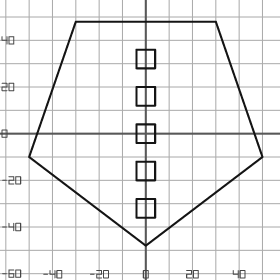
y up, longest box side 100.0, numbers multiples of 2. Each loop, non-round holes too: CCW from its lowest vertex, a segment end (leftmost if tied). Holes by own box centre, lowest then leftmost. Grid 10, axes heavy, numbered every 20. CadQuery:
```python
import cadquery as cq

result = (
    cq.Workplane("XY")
    .moveTo(0.0, -48.0)
    .lineTo(50.0, -10.0)
    .lineTo(30.0, 48.0)
    .lineTo(-30.0, 48.0)
    .lineTo(-50.0, -10.0)
    .close()
    .moveTo(-4.0, -36.0)
    .lineTo(4.0, -36.0)
    .lineTo(4.0, -28.0)
    .lineTo(-4.0, -28.0)
    .close()
    .moveTo(-4.0, -20.0)
    .lineTo(4.0, -20.0)
    .lineTo(4.0, -12.0)
    .lineTo(-4.0, -12.0)
    .close()
    .moveTo(-4.0, -4.0)
    .lineTo(4.0, -4.0)
    .lineTo(4.0, 4.0)
    .lineTo(-4.0, 4.0)
    .close()
    .moveTo(-4.0, 12.0)
    .lineTo(4.0, 12.0)
    .lineTo(4.0, 20.0)
    .lineTo(-4.0, 20.0)
    .close()
    .moveTo(-4.0, 28.0)
    .lineTo(4.0, 28.0)
    .lineTo(4.0, 36.0)
    .lineTo(-4.0, 36.0)
    .close()
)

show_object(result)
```